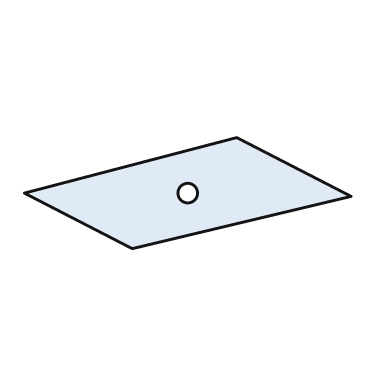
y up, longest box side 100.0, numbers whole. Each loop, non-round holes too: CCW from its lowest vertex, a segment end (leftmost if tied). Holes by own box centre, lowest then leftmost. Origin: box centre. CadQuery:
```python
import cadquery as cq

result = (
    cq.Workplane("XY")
    .moveTo(-17.0, -17.0)
    .lineTo(50.0, -1.0)
    .lineTo(15.0, 17.0)
    .lineTo(-50.0, 0.0)
    .close()
    .moveTo(0.0, 0.0)
    .circle(3.0)
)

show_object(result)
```